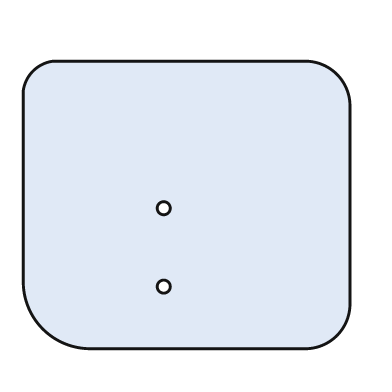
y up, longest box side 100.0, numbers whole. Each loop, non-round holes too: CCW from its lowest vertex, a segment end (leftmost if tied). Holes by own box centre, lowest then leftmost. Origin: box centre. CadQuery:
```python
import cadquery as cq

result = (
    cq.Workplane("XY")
    .moveTo(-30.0, -44.0)
    .lineTo(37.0, -44.0)
    .threePointArc((46.0, -40.0), (50.0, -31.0))
    .lineTo(50.0, 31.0)
    .threePointArc((46.0, 40.0), (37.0, 44.0))
    .lineTo(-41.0, 44.0)
    .threePointArc((-47.0, 41.0), (-50.0, 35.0))
    .lineTo(-50.0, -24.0)
    .threePointArc((-44.0, -38.0), (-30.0, -44.0))
    .close()
    .moveTo(-7.0, -25.0)
    .circle(2.0)
    .moveTo(-7.0, -1.0)
    .circle(2.0)
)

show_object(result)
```